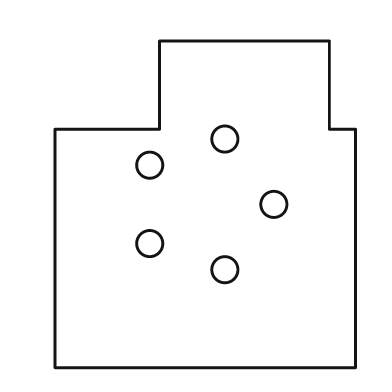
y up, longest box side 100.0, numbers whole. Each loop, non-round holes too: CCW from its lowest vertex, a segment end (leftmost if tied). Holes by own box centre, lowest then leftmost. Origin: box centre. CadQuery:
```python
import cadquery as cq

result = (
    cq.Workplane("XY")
    .moveTo(-46.0, -50.0)
    .lineTo(46.0, -50.0)
    .lineTo(46.0, 23.0)
    .lineTo(38.0, 23.0)
    .lineTo(38.0, 50.0)
    .lineTo(-14.0, 50.0)
    .lineTo(-14.0, 23.0)
    .lineTo(-46.0, 23.0)
    .close()
    .moveTo(6.0, -20.0)
    .circle(4.0)
    .moveTo(-17.0, -12.0)
    .circle(4.0)
    .moveTo(21.0, 0.0)
    .circle(4.0)
    .moveTo(-17.0, 12.0)
    .circle(4.0)
    .moveTo(6.0, 20.0)
    .circle(4.0)
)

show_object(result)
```